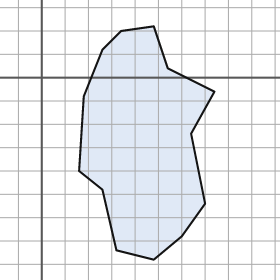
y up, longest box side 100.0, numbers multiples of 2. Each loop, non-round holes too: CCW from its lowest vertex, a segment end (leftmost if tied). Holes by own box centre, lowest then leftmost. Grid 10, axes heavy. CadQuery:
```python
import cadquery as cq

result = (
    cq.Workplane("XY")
    .moveTo(48.0, -78.0)
    .lineTo(60.0, -68.0)
    .lineTo(70.0, -54.0)
    .lineTo(64.0, -24.0)
    .lineTo(74.0, -6.0)
    .lineTo(54.0, 4.0)
    .lineTo(48.0, 22.0)
    .lineTo(34.0, 20.0)
    .lineTo(26.0, 12.0)
    .lineTo(18.0, -8.0)
    .lineTo(16.0, -40.0)
    .lineTo(26.0, -48.0)
    .lineTo(32.0, -74.0)
    .close()
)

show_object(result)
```